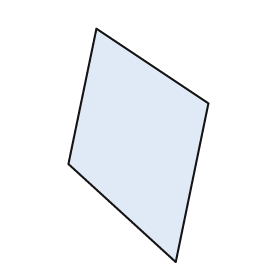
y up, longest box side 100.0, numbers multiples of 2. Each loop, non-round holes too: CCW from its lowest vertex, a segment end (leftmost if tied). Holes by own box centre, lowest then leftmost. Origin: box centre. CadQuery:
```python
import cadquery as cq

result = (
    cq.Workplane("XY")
    .moveTo(16.0, -50.0)
    .lineTo(30.0, 18.0)
    .lineTo(-18.0, 50.0)
    .lineTo(-30.0, -8.0)
    .close()
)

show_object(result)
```